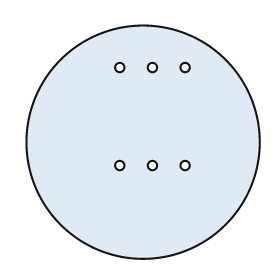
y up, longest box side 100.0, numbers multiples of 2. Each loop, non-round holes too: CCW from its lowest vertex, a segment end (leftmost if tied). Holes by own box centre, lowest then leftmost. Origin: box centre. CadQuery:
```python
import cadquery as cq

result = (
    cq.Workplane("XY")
    .moveTo(0.0, 0.0)
    .circle(50.0)
    .moveTo(-10.0, -10.0)
    .circle(2.0)
    .moveTo(4.0, -10.0)
    .circle(2.0)
    .moveTo(18.0, -10.0)
    .circle(2.0)
    .moveTo(-10.0, 32.0)
    .circle(2.0)
    .moveTo(4.0, 32.0)
    .circle(2.0)
    .moveTo(18.0, 32.0)
    .circle(2.0)
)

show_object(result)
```